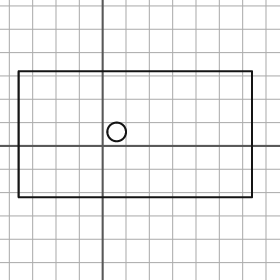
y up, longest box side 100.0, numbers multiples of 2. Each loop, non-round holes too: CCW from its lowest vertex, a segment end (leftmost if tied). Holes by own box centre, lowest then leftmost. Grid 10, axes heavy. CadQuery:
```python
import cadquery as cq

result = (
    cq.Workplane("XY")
    .moveTo(-36.0, -22.0)
    .lineTo(64.0, -22.0)
    .lineTo(64.0, 32.0)
    .lineTo(-36.0, 32.0)
    .close()
    .moveTo(6.0, 6.0)
    .circle(4.0)
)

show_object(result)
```